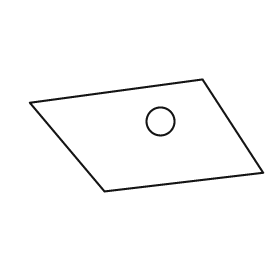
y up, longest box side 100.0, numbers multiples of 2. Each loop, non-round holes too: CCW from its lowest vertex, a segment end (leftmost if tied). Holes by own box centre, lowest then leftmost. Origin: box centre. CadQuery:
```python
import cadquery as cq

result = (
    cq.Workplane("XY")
    .moveTo(-18.0, -24.0)
    .lineTo(50.0, -16.0)
    .lineTo(24.0, 24.0)
    .lineTo(-50.0, 14.0)
    .close()
    .moveTo(6.0, 6.0)
    .circle(6.0)
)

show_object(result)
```